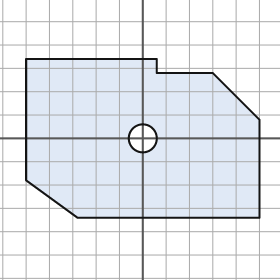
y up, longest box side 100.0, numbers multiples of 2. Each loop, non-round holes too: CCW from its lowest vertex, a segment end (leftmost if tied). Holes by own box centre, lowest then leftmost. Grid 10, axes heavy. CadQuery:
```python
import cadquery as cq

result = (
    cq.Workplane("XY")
    .moveTo(-28.0, -34.0)
    .lineTo(50.0, -34.0)
    .lineTo(50.0, 8.0)
    .lineTo(30.0, 28.0)
    .lineTo(6.0, 28.0)
    .lineTo(6.0, 34.0)
    .lineTo(-50.0, 34.0)
    .lineTo(-50.0, -18.0)
    .close()
    .moveTo(0.0, 0.0)
    .circle(6.0)
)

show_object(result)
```